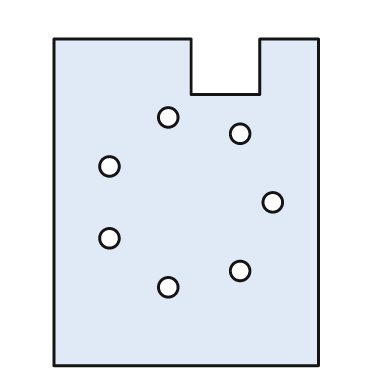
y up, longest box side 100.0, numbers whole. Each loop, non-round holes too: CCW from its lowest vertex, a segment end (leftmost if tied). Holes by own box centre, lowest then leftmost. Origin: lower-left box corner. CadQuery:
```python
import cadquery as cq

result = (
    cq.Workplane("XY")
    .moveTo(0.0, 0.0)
    .lineTo(81.0, 0.0)
    .lineTo(81.0, 100.0)
    .lineTo(63.0, 100.0)
    .lineTo(63.0, 83.0)
    .lineTo(42.0, 83.0)
    .lineTo(42.0, 100.0)
    .lineTo(0.0, 100.0)
    .close()
    .moveTo(35.0, 24.0)
    .circle(3.0)
    .moveTo(57.0, 29.0)
    .circle(3.0)
    .moveTo(17.0, 39.0)
    .circle(3.0)
    .moveTo(67.0, 50.0)
    .circle(3.0)
    .moveTo(17.0, 61.0)
    .circle(3.0)
    .moveTo(57.0, 71.0)
    .circle(3.0)
    .moveTo(35.0, 76.0)
    .circle(3.0)
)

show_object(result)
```